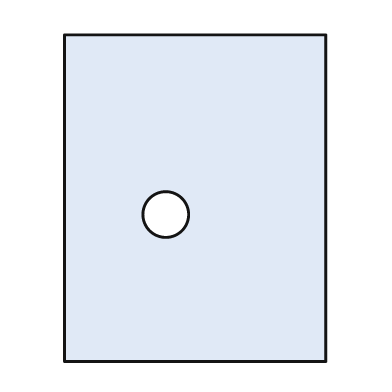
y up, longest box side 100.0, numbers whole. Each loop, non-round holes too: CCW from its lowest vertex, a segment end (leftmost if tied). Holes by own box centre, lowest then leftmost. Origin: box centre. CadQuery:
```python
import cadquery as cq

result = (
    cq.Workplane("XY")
    .moveTo(-40.0, -50.0)
    .lineTo(40.0, -50.0)
    .lineTo(40.0, 50.0)
    .lineTo(-40.0, 50.0)
    .close()
    .moveTo(-9.0, -5.0)
    .circle(7.0)
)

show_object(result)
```